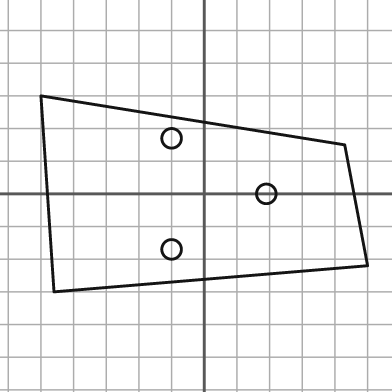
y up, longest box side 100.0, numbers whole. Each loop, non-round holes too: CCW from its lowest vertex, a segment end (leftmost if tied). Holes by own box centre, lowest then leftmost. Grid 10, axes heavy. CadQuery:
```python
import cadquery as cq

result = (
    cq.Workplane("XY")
    .moveTo(-46.0, -30.0)
    .lineTo(50.0, -22.0)
    .lineTo(43.0, 15.0)
    .lineTo(-50.0, 30.0)
    .close()
    .moveTo(-10.0, -17.0)
    .circle(3.0)
    .moveTo(19.0, 0.0)
    .circle(3.0)
    .moveTo(-10.0, 17.0)
    .circle(3.0)
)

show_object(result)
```